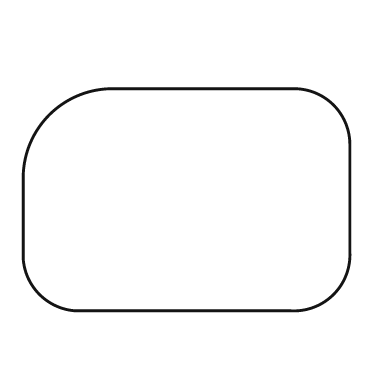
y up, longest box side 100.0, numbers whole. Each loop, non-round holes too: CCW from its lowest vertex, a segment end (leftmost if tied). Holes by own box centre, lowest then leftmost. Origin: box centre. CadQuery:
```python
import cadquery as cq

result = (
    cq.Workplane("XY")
    .moveTo(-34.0, -34.0)
    .lineTo(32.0, -34.0)
    .threePointArc((45.0, -29.0), (50.0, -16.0))
    .lineTo(50.0, 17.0)
    .threePointArc((45.0, 29.0), (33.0, 34.0))
    .lineTo(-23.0, 34.0)
    .threePointArc((-42.0, 26.0), (-50.0, 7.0))
    .lineTo(-50.0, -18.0)
    .threePointArc((-45.0, -29.0), (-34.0, -34.0))
    .close()
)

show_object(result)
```